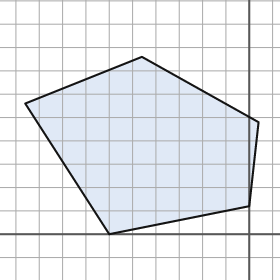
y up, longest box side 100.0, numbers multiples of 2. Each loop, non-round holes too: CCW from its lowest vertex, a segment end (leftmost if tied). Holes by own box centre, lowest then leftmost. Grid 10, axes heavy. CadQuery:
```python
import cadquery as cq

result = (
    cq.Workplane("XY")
    .moveTo(-60.0, 0.0)
    .lineTo(0.0, 12.0)
    .lineTo(4.0, 48.0)
    .lineTo(-46.0, 76.0)
    .lineTo(-96.0, 56.0)
    .close()
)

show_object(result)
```